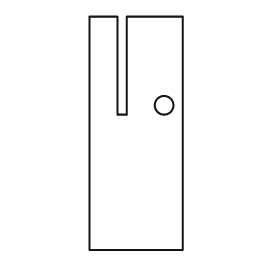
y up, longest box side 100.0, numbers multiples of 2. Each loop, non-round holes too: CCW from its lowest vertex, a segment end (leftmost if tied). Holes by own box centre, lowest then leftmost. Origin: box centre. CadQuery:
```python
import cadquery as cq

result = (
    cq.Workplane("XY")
    .moveTo(-20.0, -50.0)
    .lineTo(20.0, -50.0)
    .lineTo(20.0, 50.0)
    .lineTo(-4.0, 50.0)
    .lineTo(-4.0, 8.0)
    .lineTo(-8.0, 8.0)
    .lineTo(-8.0, 50.0)
    .lineTo(-20.0, 50.0)
    .close()
    .moveTo(12.0, 12.0)
    .circle(4.0)
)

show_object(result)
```